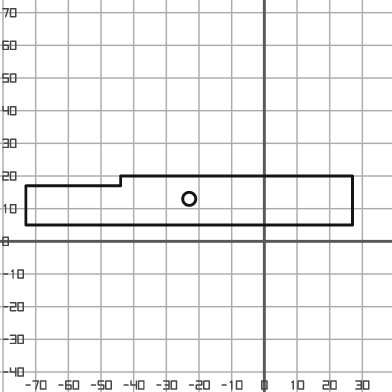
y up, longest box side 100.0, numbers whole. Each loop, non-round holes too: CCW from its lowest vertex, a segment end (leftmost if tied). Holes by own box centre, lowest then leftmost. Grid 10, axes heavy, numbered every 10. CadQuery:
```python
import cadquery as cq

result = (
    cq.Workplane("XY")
    .moveTo(-73.0, 5.0)
    .lineTo(27.0, 5.0)
    .lineTo(27.0, 20.0)
    .lineTo(-44.0, 20.0)
    .lineTo(-44.0, 17.0)
    .lineTo(-73.0, 17.0)
    .close()
    .moveTo(-23.0, 13.0)
    .circle(2.0)
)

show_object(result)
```